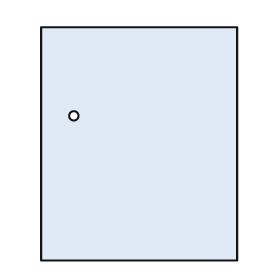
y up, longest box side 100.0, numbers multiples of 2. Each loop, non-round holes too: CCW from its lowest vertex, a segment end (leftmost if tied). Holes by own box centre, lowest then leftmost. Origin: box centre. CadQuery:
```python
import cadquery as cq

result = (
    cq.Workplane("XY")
    .moveTo(-42.0, -50.0)
    .lineTo(42.0, -50.0)
    .lineTo(42.0, 50.0)
    .lineTo(-42.0, 50.0)
    .close()
    .moveTo(-28.0, 12.0)
    .circle(2.0)
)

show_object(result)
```